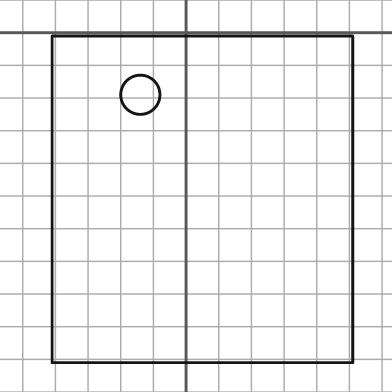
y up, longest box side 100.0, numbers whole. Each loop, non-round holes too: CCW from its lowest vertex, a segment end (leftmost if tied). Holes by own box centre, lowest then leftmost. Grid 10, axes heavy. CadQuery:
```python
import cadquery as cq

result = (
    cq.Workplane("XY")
    .moveTo(-41.0, -101.0)
    .lineTo(51.0, -101.0)
    .lineTo(51.0, -1.0)
    .lineTo(-41.0, -1.0)
    .close()
    .moveTo(-14.0, -19.0)
    .circle(6.0)
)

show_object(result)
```